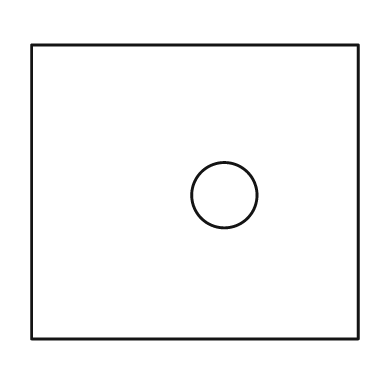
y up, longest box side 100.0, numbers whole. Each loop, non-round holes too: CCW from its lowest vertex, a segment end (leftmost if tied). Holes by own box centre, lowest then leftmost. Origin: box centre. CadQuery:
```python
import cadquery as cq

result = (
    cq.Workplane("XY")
    .moveTo(-50.0, -45.0)
    .lineTo(50.0, -45.0)
    .lineTo(50.0, 45.0)
    .lineTo(-50.0, 45.0)
    .close()
    .moveTo(9.0, -1.0)
    .circle(10.0)
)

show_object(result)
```